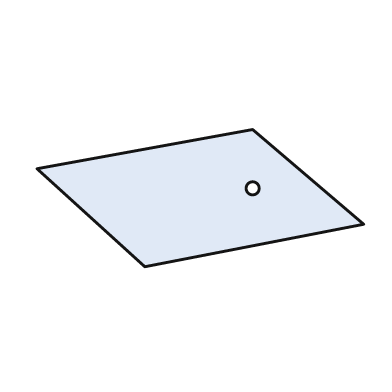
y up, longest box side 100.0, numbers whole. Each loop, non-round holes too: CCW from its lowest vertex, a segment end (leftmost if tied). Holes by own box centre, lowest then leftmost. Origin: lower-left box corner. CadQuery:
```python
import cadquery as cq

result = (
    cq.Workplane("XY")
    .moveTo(33.0, 0.0)
    .lineTo(100.0, 13.0)
    .lineTo(66.0, 42.0)
    .lineTo(0.0, 30.0)
    .close()
    .moveTo(66.0, 24.0)
    .circle(2.0)
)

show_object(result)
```